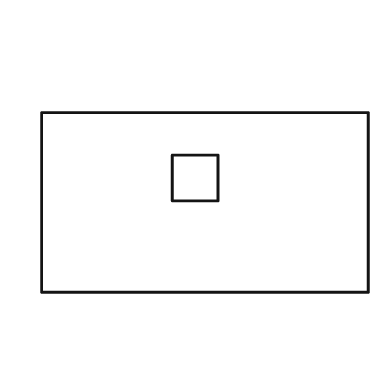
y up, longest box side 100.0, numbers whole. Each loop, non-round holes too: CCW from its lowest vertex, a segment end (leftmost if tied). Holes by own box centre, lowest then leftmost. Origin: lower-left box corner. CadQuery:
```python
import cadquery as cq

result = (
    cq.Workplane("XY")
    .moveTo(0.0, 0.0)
    .lineTo(100.0, 0.0)
    .lineTo(100.0, 55.0)
    .lineTo(0.0, 55.0)
    .close()
    .moveTo(40.0, 28.0)
    .lineTo(54.0, 28.0)
    .lineTo(54.0, 42.0)
    .lineTo(40.0, 42.0)
    .close()
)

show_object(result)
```